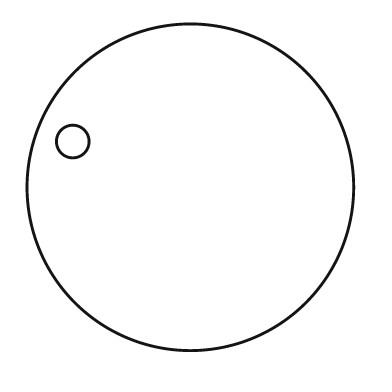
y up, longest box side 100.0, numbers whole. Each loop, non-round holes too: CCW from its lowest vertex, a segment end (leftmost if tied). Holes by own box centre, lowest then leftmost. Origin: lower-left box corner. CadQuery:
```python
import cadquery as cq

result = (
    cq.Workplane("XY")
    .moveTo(50.0, 50.0)
    .circle(50.0)
    .moveTo(14.0, 64.0)
    .circle(5.0)
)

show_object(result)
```